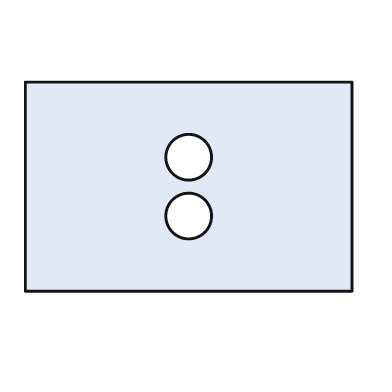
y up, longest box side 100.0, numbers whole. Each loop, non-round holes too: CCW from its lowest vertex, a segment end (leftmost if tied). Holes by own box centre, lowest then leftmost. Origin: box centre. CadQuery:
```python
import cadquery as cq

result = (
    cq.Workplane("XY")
    .moveTo(-50.0, -32.0)
    .lineTo(50.0, -32.0)
    .lineTo(50.0, 32.0)
    .lineTo(-50.0, 32.0)
    .close()
    .moveTo(0.0, -9.0)
    .circle(7.0)
    .moveTo(0.0, 9.0)
    .circle(7.0)
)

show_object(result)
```